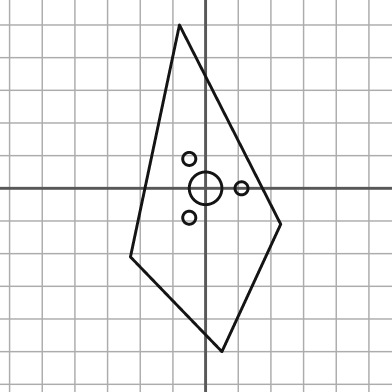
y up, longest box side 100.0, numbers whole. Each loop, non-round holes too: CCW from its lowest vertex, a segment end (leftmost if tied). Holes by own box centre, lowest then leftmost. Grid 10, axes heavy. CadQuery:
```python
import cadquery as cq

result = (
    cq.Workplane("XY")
    .moveTo(5.0, -50.0)
    .lineTo(23.0, -11.0)
    .lineTo(-8.0, 50.0)
    .lineTo(-23.0, -21.0)
    .close()
    .moveTo(-5.0, -9.0)
    .circle(2.0)
    .moveTo(0.0, 0.0)
    .circle(5.0)
    .moveTo(11.0, 0.0)
    .circle(2.0)
    .moveTo(-5.0, 9.0)
    .circle(2.0)
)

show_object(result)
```